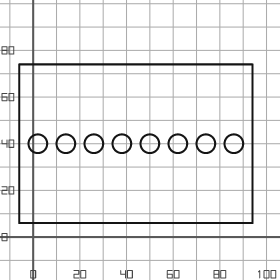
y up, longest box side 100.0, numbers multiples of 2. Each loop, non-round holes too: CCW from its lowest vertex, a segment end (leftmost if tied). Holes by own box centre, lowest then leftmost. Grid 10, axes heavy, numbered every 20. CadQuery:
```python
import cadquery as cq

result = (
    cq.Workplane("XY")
    .moveTo(-6.0, 6.0)
    .lineTo(94.0, 6.0)
    .lineTo(94.0, 74.0)
    .lineTo(-6.0, 74.0)
    .close()
    .moveTo(2.0, 40.0)
    .circle(4.0)
    .moveTo(14.0, 40.0)
    .circle(4.0)
    .moveTo(26.0, 40.0)
    .circle(4.0)
    .moveTo(38.0, 40.0)
    .circle(4.0)
    .moveTo(50.0, 40.0)
    .circle(4.0)
    .moveTo(62.0, 40.0)
    .circle(4.0)
    .moveTo(74.0, 40.0)
    .circle(4.0)
    .moveTo(86.0, 40.0)
    .circle(4.0)
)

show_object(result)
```